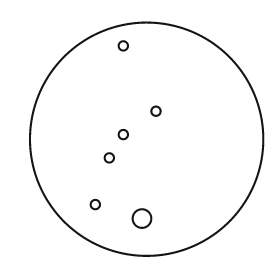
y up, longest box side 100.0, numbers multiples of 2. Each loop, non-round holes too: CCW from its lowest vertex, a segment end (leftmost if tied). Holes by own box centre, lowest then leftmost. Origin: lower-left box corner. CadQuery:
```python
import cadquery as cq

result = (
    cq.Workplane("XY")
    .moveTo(50.0, 50.0)
    .circle(50.0)
    .moveTo(48.0, 16.0)
    .circle(4.0)
    .moveTo(28.0, 22.0)
    .circle(2.0)
    .moveTo(34.0, 42.0)
    .circle(2.0)
    .moveTo(40.0, 52.0)
    .circle(2.0)
    .moveTo(54.0, 62.0)
    .circle(2.0)
    .moveTo(40.0, 90.0)
    .circle(2.0)
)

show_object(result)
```